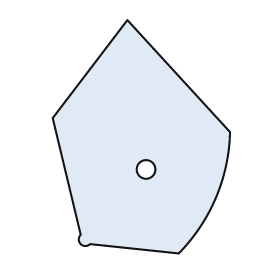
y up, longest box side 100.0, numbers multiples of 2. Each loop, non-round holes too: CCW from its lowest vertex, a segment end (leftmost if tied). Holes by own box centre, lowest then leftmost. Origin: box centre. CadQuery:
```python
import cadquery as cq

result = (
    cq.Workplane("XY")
    .moveTo(16.0, -50.0)
    .threePointArc((32.0, -26.0), (38.0, 2.0))
    .lineTo(-6.0, 50.0)
    .lineTo(-38.0, 8.0)
    .lineTo(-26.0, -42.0)
    .threePointArc((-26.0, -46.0), (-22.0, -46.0))
    .close()
    .moveTo(2.0, -14.0)
    .circle(4.0)
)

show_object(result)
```